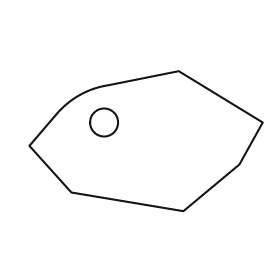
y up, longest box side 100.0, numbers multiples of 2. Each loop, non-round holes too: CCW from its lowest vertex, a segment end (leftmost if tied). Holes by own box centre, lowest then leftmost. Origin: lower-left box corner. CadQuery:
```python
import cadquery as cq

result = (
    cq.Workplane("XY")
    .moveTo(66.0, 0.0)
    .lineTo(90.0, 20.0)
    .lineTo(100.0, 38.0)
    .lineTo(64.0, 60.0)
    .lineTo(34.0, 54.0)
    .threePointArc((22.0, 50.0), (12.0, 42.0))
    .lineTo(0.0, 28.0)
    .lineTo(18.0, 8.0)
    .close()
    .moveTo(32.0, 38.0)
    .circle(6.0)
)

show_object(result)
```